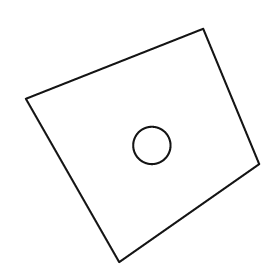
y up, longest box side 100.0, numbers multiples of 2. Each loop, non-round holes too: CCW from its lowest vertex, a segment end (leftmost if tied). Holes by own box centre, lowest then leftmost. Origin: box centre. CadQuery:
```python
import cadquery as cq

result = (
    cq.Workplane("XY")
    .moveTo(-10.0, -50.0)
    .lineTo(50.0, -8.0)
    .lineTo(26.0, 50.0)
    .lineTo(-50.0, 20.0)
    .close()
    .moveTo(4.0, 0.0)
    .circle(8.0)
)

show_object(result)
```